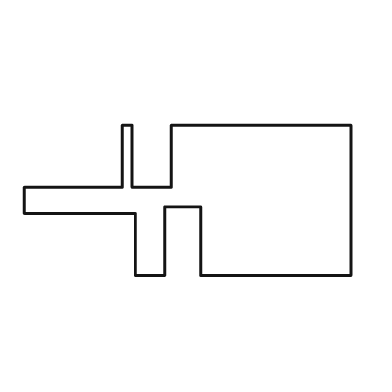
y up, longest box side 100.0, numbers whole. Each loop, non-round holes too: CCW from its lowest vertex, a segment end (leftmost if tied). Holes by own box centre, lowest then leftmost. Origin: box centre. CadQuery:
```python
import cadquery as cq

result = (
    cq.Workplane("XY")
    .moveTo(-16.0, -23.0)
    .lineTo(-7.0, -23.0)
    .lineTo(-7.0, -2.0)
    .lineTo(4.0, -2.0)
    .lineTo(4.0, -23.0)
    .lineTo(50.0, -23.0)
    .lineTo(50.0, 23.0)
    .lineTo(-5.0, 23.0)
    .lineTo(-5.0, 4.0)
    .lineTo(-17.0, 4.0)
    .lineTo(-17.0, 23.0)
    .lineTo(-20.0, 23.0)
    .lineTo(-20.0, 4.0)
    .lineTo(-50.0, 4.0)
    .lineTo(-50.0, -4.0)
    .lineTo(-16.0, -4.0)
    .close()
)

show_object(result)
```